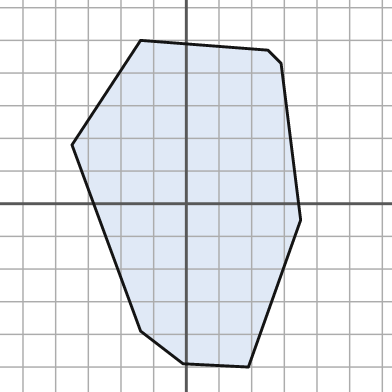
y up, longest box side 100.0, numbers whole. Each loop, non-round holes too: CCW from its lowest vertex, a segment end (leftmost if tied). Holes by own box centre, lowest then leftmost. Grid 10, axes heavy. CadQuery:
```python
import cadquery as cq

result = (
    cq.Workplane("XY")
    .moveTo(19.0, -50.0)
    .lineTo(35.0, -5.0)
    .lineTo(29.0, 43.0)
    .lineTo(25.0, 47.0)
    .lineTo(-14.0, 50.0)
    .lineTo(-35.0, 18.0)
    .lineTo(-14.0, -39.0)
    .lineTo(-1.0, -49.0)
    .close()
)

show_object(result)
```